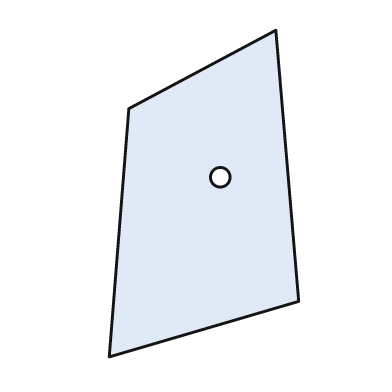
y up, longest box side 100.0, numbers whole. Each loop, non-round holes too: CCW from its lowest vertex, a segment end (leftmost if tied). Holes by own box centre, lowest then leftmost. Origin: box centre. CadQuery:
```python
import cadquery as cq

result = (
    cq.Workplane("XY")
    .moveTo(-29.0, -50.0)
    .lineTo(29.0, -33.0)
    .lineTo(22.0, 50.0)
    .lineTo(-23.0, 26.0)
    .close()
    .moveTo(5.0, 5.0)
    .circle(3.0)
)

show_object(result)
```